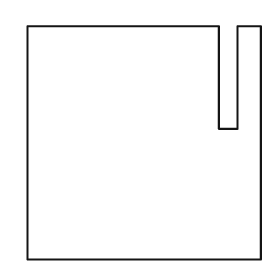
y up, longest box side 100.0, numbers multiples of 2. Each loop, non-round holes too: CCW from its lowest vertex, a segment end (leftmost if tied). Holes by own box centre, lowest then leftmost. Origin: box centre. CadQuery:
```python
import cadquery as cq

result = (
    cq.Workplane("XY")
    .moveTo(-50.0, -50.0)
    .lineTo(50.0, -50.0)
    .lineTo(50.0, 50.0)
    .lineTo(40.0, 50.0)
    .lineTo(40.0, 6.0)
    .lineTo(32.0, 6.0)
    .lineTo(32.0, 50.0)
    .lineTo(-50.0, 50.0)
    .close()
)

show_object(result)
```